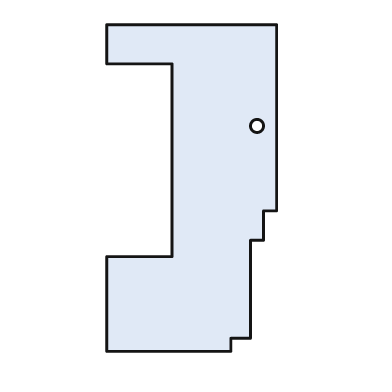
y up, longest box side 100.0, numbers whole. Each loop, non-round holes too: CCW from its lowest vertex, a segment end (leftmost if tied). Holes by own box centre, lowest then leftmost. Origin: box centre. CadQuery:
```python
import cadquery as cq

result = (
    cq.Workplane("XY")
    .moveTo(-26.0, -50.0)
    .lineTo(12.0, -50.0)
    .lineTo(12.0, -46.0)
    .lineTo(18.0, -46.0)
    .lineTo(18.0, -16.0)
    .lineTo(22.0, -16.0)
    .lineTo(22.0, -7.0)
    .lineTo(26.0, -7.0)
    .lineTo(26.0, 50.0)
    .lineTo(-26.0, 50.0)
    .lineTo(-26.0, 38.0)
    .lineTo(-6.0, 38.0)
    .lineTo(-6.0, -21.0)
    .lineTo(-26.0, -21.0)
    .close()
    .moveTo(20.0, 19.0)
    .circle(2.0)
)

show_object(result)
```